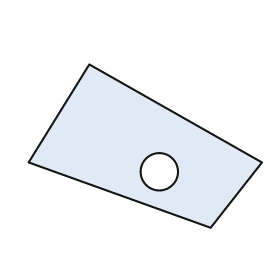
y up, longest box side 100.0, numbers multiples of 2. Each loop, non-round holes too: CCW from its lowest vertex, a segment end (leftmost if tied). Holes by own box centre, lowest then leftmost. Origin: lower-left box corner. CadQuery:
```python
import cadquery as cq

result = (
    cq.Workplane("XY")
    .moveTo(78.0, 0.0)
    .lineTo(100.0, 28.0)
    .lineTo(26.0, 70.0)
    .lineTo(0.0, 28.0)
    .close()
    .moveTo(56.0, 24.0)
    .circle(8.0)
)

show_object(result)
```